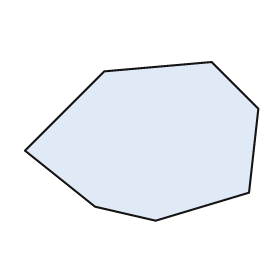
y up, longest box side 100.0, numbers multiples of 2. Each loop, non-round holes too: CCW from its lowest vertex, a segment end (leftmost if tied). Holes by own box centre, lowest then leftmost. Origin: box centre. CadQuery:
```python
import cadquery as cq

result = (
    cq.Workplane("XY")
    .moveTo(6.0, -34.0)
    .lineTo(46.0, -22.0)
    .lineTo(50.0, 14.0)
    .lineTo(30.0, 34.0)
    .lineTo(-16.0, 30.0)
    .lineTo(-50.0, -4.0)
    .lineTo(-20.0, -28.0)
    .close()
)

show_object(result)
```